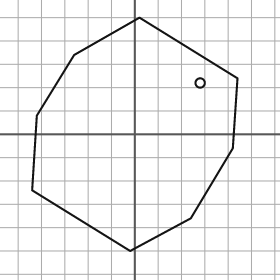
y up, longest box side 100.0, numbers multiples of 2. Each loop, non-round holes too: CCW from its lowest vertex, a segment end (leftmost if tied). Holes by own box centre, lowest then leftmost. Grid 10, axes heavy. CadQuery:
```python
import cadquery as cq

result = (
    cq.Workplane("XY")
    .moveTo(-2.0, -50.0)
    .lineTo(24.0, -36.0)
    .lineTo(42.0, -6.0)
    .lineTo(44.0, 24.0)
    .lineTo(2.0, 50.0)
    .lineTo(-26.0, 34.0)
    .lineTo(-42.0, 8.0)
    .lineTo(-44.0, -24.0)
    .close()
    .moveTo(28.0, 22.0)
    .circle(2.0)
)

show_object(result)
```